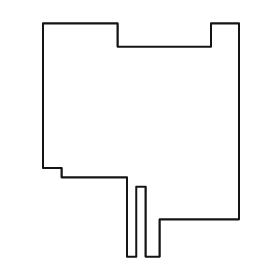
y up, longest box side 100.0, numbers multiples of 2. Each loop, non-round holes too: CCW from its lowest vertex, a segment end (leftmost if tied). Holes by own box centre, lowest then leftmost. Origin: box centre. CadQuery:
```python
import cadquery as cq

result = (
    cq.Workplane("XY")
    .moveTo(-6.0, -50.0)
    .lineTo(-2.0, -50.0)
    .lineTo(-2.0, -20.0)
    .lineTo(2.0, -20.0)
    .lineTo(2.0, -50.0)
    .lineTo(8.0, -50.0)
    .lineTo(8.0, -34.0)
    .lineTo(42.0, -34.0)
    .lineTo(42.0, 50.0)
    .lineTo(30.0, 50.0)
    .lineTo(30.0, 40.0)
    .lineTo(-10.0, 40.0)
    .lineTo(-10.0, 50.0)
    .lineTo(-42.0, 50.0)
    .lineTo(-42.0, -12.0)
    .lineTo(-34.0, -12.0)
    .lineTo(-34.0, -16.0)
    .lineTo(-6.0, -16.0)
    .close()
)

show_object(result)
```